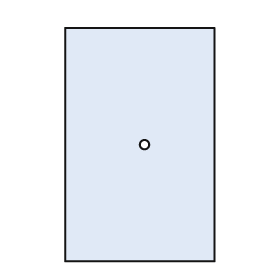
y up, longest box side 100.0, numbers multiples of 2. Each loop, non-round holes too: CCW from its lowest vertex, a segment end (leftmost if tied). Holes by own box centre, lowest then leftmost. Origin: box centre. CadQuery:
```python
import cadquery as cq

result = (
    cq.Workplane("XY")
    .moveTo(-32.0, -50.0)
    .lineTo(32.0, -50.0)
    .lineTo(32.0, 50.0)
    .lineTo(-32.0, 50.0)
    .close()
    .moveTo(2.0, 0.0)
    .circle(2.0)
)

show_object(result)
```